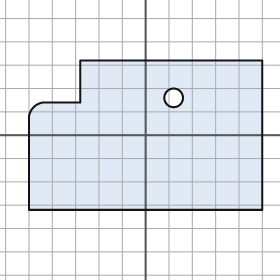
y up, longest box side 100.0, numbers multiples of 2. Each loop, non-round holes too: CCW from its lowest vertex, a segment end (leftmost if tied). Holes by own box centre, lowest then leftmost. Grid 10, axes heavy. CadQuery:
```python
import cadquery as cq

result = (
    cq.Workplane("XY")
    .moveTo(-50.0, -32.0)
    .lineTo(50.0, -32.0)
    .lineTo(50.0, 32.0)
    .lineTo(-28.0, 32.0)
    .lineTo(-28.0, 14.0)
    .lineTo(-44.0, 14.0)
    .threePointArc((-48.0, 12.0), (-50.0, 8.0))
    .close()
    .moveTo(12.0, 16.0)
    .circle(4.0)
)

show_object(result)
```